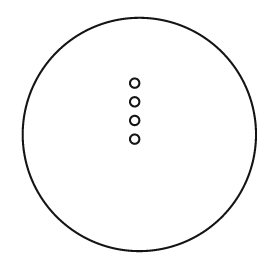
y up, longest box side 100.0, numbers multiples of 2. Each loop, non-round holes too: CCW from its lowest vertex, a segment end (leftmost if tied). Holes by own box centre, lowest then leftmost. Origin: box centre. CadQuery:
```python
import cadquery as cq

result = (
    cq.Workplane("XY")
    .moveTo(0.0, 0.0)
    .circle(50.0)
    .moveTo(-2.0, -2.0)
    .circle(2.0)
    .moveTo(-2.0, 6.0)
    .circle(2.0)
    .moveTo(-2.0, 14.0)
    .circle(2.0)
    .moveTo(-2.0, 22.0)
    .circle(2.0)
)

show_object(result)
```